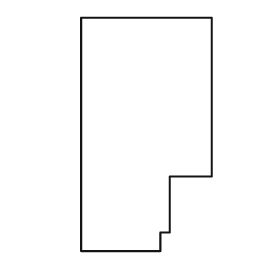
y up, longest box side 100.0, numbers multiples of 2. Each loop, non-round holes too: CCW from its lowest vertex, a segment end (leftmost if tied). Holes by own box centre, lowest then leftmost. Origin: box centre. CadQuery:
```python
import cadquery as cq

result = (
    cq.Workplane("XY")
    .moveTo(-28.0, -50.0)
    .lineTo(6.0, -50.0)
    .lineTo(6.0, -42.0)
    .lineTo(10.0, -42.0)
    .lineTo(10.0, -18.0)
    .lineTo(28.0, -18.0)
    .lineTo(28.0, 50.0)
    .lineTo(-28.0, 50.0)
    .close()
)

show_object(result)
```